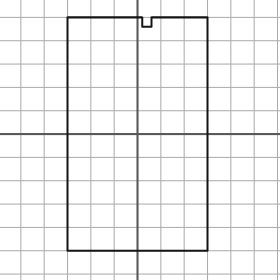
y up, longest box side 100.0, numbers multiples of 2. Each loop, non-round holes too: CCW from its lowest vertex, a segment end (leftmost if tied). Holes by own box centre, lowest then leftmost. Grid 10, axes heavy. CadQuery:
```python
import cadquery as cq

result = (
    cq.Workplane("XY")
    .moveTo(-30.0, -50.0)
    .lineTo(30.0, -50.0)
    .lineTo(30.0, 50.0)
    .lineTo(6.0, 50.0)
    .lineTo(6.0, 46.0)
    .lineTo(2.0, 46.0)
    .lineTo(2.0, 50.0)
    .lineTo(-30.0, 50.0)
    .close()
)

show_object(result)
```